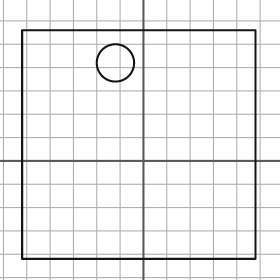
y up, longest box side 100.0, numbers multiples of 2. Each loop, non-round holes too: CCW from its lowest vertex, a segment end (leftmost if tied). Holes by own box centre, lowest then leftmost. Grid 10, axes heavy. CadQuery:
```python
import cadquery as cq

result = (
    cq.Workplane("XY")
    .moveTo(-52.0, -42.0)
    .lineTo(48.0, -42.0)
    .lineTo(48.0, 56.0)
    .lineTo(-52.0, 56.0)
    .close()
    .moveTo(-12.0, 42.0)
    .circle(8.0)
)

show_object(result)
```